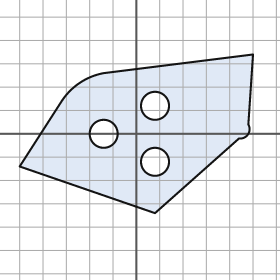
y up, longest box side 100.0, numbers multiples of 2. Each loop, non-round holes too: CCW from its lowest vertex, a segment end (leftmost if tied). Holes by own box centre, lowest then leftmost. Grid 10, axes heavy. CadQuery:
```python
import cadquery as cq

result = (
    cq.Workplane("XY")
    .moveTo(8.0, -34.0)
    .lineTo(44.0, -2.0)
    .threePointArc((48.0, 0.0), (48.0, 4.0))
    .lineTo(50.0, 34.0)
    .lineTo(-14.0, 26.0)
    .threePointArc((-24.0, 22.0), (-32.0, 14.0))
    .lineTo(-50.0, -14.0)
    .close()
    .moveTo(8.0, -12.0)
    .circle(6.0)
    .moveTo(-14.0, 0.0)
    .circle(6.0)
    .moveTo(8.0, 12.0)
    .circle(6.0)
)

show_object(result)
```